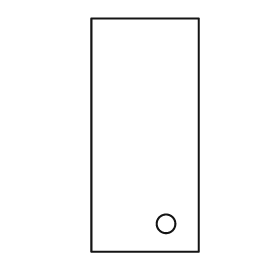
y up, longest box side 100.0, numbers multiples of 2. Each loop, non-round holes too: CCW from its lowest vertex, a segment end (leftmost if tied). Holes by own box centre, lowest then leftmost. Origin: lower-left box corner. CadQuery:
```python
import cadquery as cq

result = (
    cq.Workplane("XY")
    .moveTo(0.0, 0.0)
    .lineTo(46.0, 0.0)
    .lineTo(46.0, 100.0)
    .lineTo(0.0, 100.0)
    .close()
    .moveTo(32.0, 12.0)
    .circle(4.0)
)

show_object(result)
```